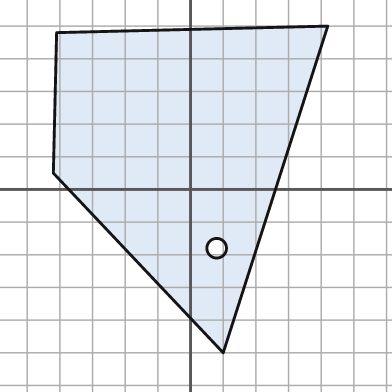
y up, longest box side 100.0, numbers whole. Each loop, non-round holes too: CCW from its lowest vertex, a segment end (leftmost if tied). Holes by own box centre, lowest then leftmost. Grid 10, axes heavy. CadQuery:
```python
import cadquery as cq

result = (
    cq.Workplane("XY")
    .moveTo(10.0, -50.0)
    .lineTo(42.0, 50.0)
    .lineTo(-41.0, 48.0)
    .lineTo(-42.0, 5.0)
    .close()
    .moveTo(8.0, -18.0)
    .circle(3.0)
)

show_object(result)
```